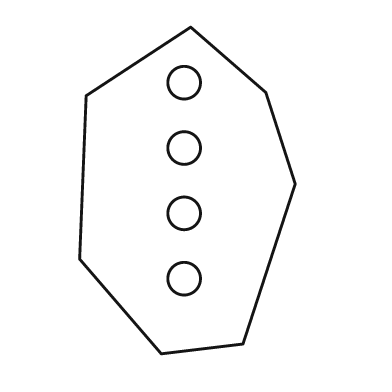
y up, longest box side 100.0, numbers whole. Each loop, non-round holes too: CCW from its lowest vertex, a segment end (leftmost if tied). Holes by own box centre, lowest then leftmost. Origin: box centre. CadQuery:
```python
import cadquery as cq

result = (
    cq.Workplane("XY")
    .moveTo(-8.0, -50.0)
    .lineTo(17.0, -47.0)
    .lineTo(33.0, 2.0)
    .lineTo(24.0, 30.0)
    .lineTo(1.0, 50.0)
    .lineTo(-31.0, 29.0)
    .lineTo(-33.0, -21.0)
    .close()
    .moveTo(-1.0, -27.0)
    .circle(5.0)
    .moveTo(-1.0, -7.0)
    .circle(5.0)
    .moveTo(-1.0, 13.0)
    .circle(5.0)
    .moveTo(-1.0, 33.0)
    .circle(5.0)
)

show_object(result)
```